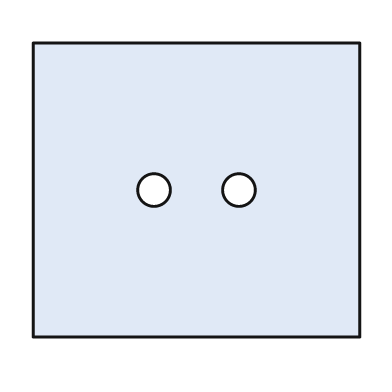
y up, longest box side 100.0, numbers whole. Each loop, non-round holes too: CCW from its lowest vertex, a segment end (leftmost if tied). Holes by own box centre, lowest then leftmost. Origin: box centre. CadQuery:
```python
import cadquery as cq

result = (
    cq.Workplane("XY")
    .moveTo(-50.0, -45.0)
    .lineTo(50.0, -45.0)
    .lineTo(50.0, 45.0)
    .lineTo(-50.0, 45.0)
    .close()
    .moveTo(-13.0, 0.0)
    .circle(5.0)
    .moveTo(13.0, 0.0)
    .circle(5.0)
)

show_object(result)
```